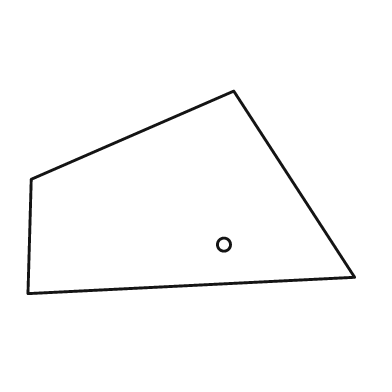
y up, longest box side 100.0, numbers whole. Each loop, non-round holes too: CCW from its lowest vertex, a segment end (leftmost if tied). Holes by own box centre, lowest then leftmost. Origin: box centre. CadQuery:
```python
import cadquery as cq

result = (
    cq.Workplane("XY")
    .moveTo(-50.0, -31.0)
    .lineTo(50.0, -26.0)
    .lineTo(13.0, 31.0)
    .lineTo(-49.0, 4.0)
    .close()
    .moveTo(10.0, -16.0)
    .circle(2.0)
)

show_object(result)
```